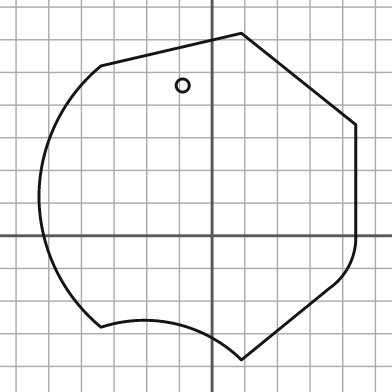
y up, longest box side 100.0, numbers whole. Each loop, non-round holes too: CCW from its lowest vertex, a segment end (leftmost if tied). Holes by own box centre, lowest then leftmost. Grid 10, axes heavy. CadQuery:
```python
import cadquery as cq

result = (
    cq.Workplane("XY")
    .moveTo(9.0, -38.0)
    .lineTo(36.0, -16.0)
    .threePointArc((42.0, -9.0), (44.0, 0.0))
    .lineTo(44.0, 34.0)
    .lineTo(9.0, 62.0)
    .lineTo(-34.0, 52.0)
    .threePointArc((-48.0, 34.0), (-53.0, 12.0))
    .threePointArc((-48.0, -10.0), (-34.0, -28.0))
    .threePointArc((-11.0, -27.0), (9.0, -38.0))
    .close()
    .moveTo(-9.0, 46.0)
    .circle(2.0)
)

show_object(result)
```